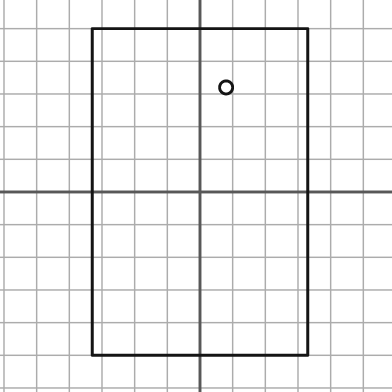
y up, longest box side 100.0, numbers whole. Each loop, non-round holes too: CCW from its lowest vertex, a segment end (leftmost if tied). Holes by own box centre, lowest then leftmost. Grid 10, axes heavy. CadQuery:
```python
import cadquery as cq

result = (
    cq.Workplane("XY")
    .moveTo(-33.0, -50.0)
    .lineTo(33.0, -50.0)
    .lineTo(33.0, 50.0)
    .lineTo(-33.0, 50.0)
    .close()
    .moveTo(8.0, 32.0)
    .circle(2.0)
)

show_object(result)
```